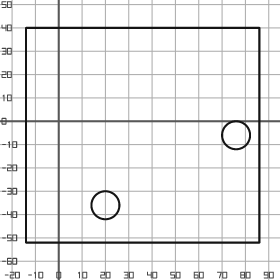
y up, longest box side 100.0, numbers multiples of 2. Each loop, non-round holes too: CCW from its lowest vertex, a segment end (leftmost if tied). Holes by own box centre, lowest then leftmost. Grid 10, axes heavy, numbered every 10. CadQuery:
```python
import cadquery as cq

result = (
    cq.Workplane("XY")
    .moveTo(-14.0, -52.0)
    .lineTo(86.0, -52.0)
    .lineTo(86.0, 40.0)
    .lineTo(-14.0, 40.0)
    .close()
    .moveTo(20.0, -36.0)
    .circle(6.0)
    .moveTo(76.0, -6.0)
    .circle(6.0)
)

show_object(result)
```